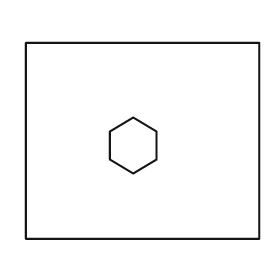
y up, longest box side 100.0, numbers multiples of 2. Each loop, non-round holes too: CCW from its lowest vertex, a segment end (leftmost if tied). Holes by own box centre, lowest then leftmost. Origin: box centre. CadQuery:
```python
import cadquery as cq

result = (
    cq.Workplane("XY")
    .moveTo(-50.0, -42.0)
    .lineTo(50.0, -42.0)
    .lineTo(50.0, 42.0)
    .lineTo(-50.0, 42.0)
    .close()
    .moveTo(-4.0, -14.0)
    .lineTo(6.0, -8.0)
    .lineTo(6.0, 4.0)
    .lineTo(-4.0, 10.0)
    .lineTo(-14.0, 4.0)
    .lineTo(-14.0, -8.0)
    .close()
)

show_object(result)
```